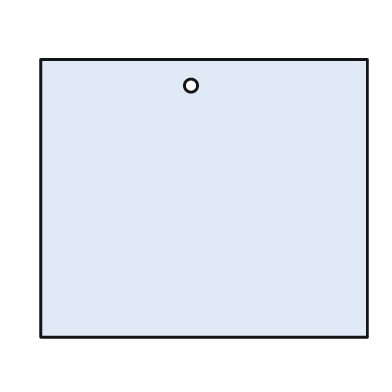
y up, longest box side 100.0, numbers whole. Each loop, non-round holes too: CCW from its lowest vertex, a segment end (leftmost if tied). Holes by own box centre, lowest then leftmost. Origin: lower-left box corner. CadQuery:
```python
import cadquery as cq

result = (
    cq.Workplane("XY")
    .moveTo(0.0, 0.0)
    .lineTo(100.0, 0.0)
    .lineTo(100.0, 85.0)
    .lineTo(0.0, 85.0)
    .close()
    .moveTo(46.0, 77.0)
    .circle(2.0)
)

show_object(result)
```